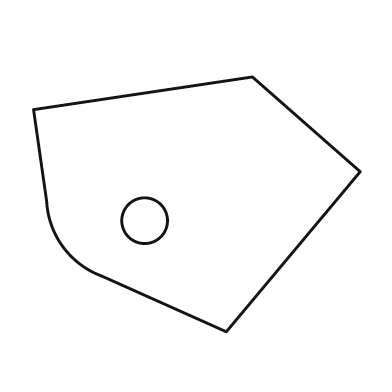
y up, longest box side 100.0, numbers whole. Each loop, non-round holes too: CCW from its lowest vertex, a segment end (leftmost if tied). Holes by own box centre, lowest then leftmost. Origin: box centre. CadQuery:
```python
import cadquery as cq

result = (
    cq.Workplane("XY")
    .moveTo(9.0, -39.0)
    .lineTo(50.0, 10.0)
    .lineTo(17.0, 39.0)
    .lineTo(-50.0, 29.0)
    .lineTo(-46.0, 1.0)
    .threePointArc((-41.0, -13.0), (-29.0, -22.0))
    .close()
    .moveTo(-16.0, -5.0)
    .circle(7.0)
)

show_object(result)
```